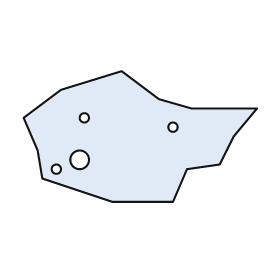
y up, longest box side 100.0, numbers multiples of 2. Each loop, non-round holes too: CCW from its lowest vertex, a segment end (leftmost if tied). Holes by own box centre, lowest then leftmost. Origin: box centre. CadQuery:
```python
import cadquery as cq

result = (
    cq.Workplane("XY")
    .moveTo(-12.0, -28.0)
    .lineTo(14.0, -28.0)
    .lineTo(20.0, -14.0)
    .lineTo(34.0, -12.0)
    .lineTo(40.0, 0.0)
    .lineTo(50.0, 12.0)
    .lineTo(22.0, 12.0)
    .lineTo(8.0, 16.0)
    .lineTo(-8.0, 28.0)
    .lineTo(-34.0, 20.0)
    .lineTo(-50.0, 8.0)
    .lineTo(-44.0, -6.0)
    .lineTo(-42.0, -18.0)
    .close()
    .moveTo(-36.0, -14.0)
    .circle(2.0)
    .moveTo(-26.0, -10.0)
    .circle(4.0)
    .moveTo(14.0, 4.0)
    .circle(2.0)
    .moveTo(-24.0, 8.0)
    .circle(2.0)
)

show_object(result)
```